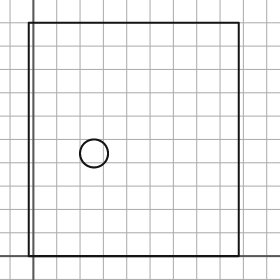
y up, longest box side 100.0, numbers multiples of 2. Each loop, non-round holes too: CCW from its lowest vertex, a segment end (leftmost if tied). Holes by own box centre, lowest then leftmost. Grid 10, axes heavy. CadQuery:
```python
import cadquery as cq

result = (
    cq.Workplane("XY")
    .moveTo(-2.0, 0.0)
    .lineTo(88.0, 0.0)
    .lineTo(88.0, 100.0)
    .lineTo(-2.0, 100.0)
    .close()
    .moveTo(26.0, 44.0)
    .circle(6.0)
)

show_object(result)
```